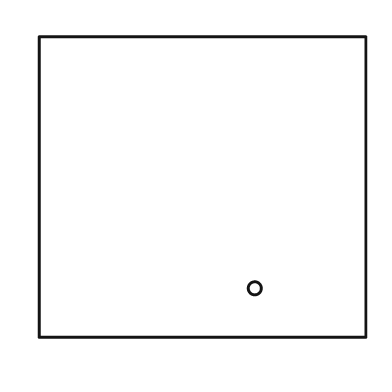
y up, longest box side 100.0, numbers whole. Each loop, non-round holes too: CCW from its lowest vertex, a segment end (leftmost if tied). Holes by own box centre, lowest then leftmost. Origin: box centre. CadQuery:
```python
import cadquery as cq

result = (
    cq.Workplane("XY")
    .moveTo(-50.0, -46.0)
    .lineTo(50.0, -46.0)
    .lineTo(50.0, 46.0)
    .lineTo(-50.0, 46.0)
    .close()
    .moveTo(16.0, -31.0)
    .circle(2.0)
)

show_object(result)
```